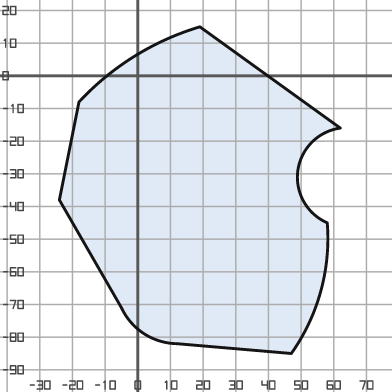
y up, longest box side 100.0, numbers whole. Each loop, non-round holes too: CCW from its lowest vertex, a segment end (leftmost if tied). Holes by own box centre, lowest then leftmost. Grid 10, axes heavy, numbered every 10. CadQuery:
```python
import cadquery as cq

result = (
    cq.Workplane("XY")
    .moveTo(47.0, -85.0)
    .threePointArc((56.0, -66.0), (58.0, -45.0))
    .threePointArc((49.0, -29.0), (62.0, -16.0))
    .lineTo(19.0, 15.0)
    .threePointArc((-1.0, 6.0), (-18.0, -8.0))
    .lineTo(-24.0, -38.0)
    .lineTo(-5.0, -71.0)
    .threePointArc((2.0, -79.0), (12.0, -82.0))
    .close()
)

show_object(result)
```